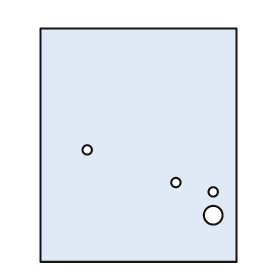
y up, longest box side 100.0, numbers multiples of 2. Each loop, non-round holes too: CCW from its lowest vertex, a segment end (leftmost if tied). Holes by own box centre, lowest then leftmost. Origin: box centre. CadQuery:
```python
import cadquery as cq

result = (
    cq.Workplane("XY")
    .moveTo(-42.0, -50.0)
    .lineTo(42.0, -50.0)
    .lineTo(42.0, 50.0)
    .lineTo(-42.0, 50.0)
    .close()
    .moveTo(32.0, -30.0)
    .circle(4.0)
    .moveTo(32.0, -20.0)
    .circle(2.0)
    .moveTo(16.0, -16.0)
    .circle(2.0)
    .moveTo(-22.0, -2.0)
    .circle(2.0)
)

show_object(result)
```